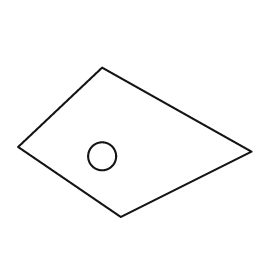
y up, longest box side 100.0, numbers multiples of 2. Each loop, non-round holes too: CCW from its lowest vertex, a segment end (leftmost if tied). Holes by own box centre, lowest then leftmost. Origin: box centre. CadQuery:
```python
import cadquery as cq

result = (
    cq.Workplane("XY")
    .moveTo(-6.0, -32.0)
    .lineTo(50.0, -4.0)
    .lineTo(-14.0, 32.0)
    .lineTo(-50.0, -2.0)
    .close()
    .moveTo(-14.0, -6.0)
    .circle(6.0)
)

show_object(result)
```